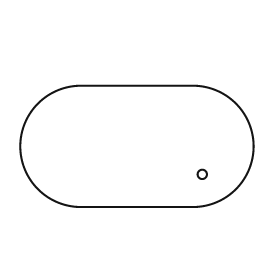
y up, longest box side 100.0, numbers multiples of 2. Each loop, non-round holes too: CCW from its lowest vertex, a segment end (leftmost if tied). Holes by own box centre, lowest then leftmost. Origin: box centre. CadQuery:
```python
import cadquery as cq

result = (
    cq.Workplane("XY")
    .moveTo(-24.0, -26.0)
    .lineTo(24.0, -26.0)
    .threePointArc((50.0, 0.0), (24.0, 26.0))
    .lineTo(-24.0, 26.0)
    .threePointArc((-50.0, 0.0), (-24.0, -26.0))
    .close()
    .moveTo(28.0, -12.0)
    .circle(2.0)
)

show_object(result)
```